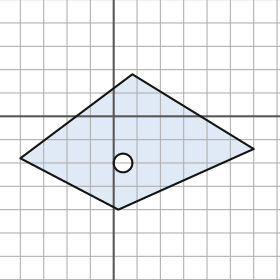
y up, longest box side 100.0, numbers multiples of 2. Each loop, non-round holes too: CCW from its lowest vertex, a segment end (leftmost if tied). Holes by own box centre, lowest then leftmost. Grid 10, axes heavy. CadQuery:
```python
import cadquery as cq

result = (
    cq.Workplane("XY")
    .moveTo(2.0, -40.0)
    .lineTo(60.0, -14.0)
    .lineTo(8.0, 18.0)
    .lineTo(-40.0, -18.0)
    .close()
    .moveTo(4.0, -20.0)
    .circle(4.0)
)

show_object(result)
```